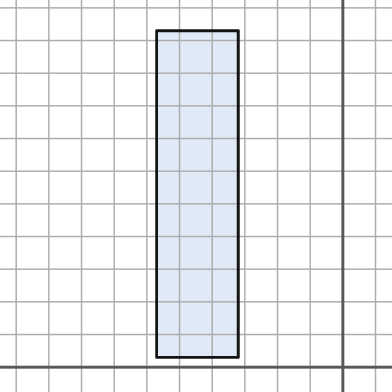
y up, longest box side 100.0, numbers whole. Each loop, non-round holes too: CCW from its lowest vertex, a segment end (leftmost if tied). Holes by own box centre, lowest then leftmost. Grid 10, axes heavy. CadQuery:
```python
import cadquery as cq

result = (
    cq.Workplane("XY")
    .moveTo(-57.0, 3.0)
    .lineTo(-32.0, 3.0)
    .lineTo(-32.0, 103.0)
    .lineTo(-57.0, 103.0)
    .close()
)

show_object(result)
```